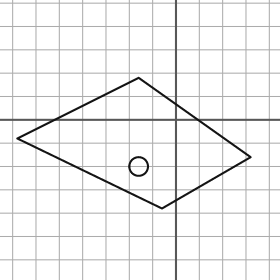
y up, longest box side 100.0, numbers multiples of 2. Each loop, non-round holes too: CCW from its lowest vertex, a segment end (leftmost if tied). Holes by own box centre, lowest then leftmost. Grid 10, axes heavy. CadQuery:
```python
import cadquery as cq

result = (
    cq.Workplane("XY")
    .moveTo(-6.0, -38.0)
    .lineTo(32.0, -16.0)
    .lineTo(-16.0, 18.0)
    .lineTo(-68.0, -8.0)
    .close()
    .moveTo(-16.0, -20.0)
    .circle(4.0)
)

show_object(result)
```